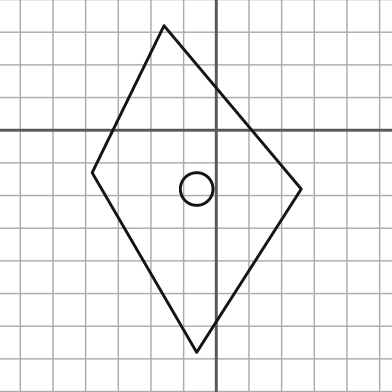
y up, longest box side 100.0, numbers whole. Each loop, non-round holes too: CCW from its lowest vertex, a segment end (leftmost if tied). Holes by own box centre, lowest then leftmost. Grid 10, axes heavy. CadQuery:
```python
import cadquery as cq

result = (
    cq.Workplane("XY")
    .moveTo(-6.0, -68.0)
    .lineTo(26.0, -18.0)
    .lineTo(-16.0, 32.0)
    .lineTo(-38.0, -13.0)
    .close()
    .moveTo(-6.0, -18.0)
    .circle(5.0)
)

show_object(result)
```